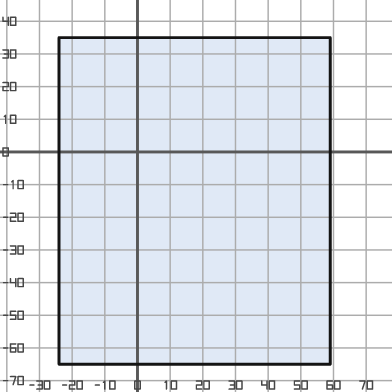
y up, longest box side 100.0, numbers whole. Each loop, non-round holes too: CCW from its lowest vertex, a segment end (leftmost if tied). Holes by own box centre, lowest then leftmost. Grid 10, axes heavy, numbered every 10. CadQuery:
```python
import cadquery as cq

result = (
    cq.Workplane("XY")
    .moveTo(-24.0, -65.0)
    .lineTo(59.0, -65.0)
    .lineTo(59.0, 35.0)
    .lineTo(-24.0, 35.0)
    .close()
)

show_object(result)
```